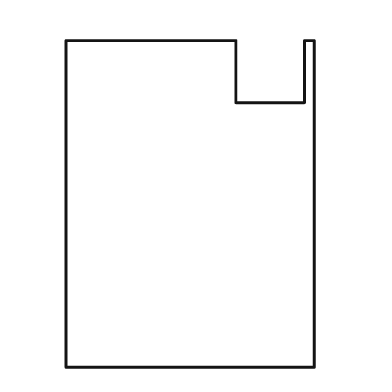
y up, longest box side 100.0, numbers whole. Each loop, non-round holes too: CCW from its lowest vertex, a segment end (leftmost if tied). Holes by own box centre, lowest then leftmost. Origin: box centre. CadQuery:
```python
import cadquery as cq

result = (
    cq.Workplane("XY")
    .moveTo(-38.0, -50.0)
    .lineTo(38.0, -50.0)
    .lineTo(38.0, 50.0)
    .lineTo(35.0, 50.0)
    .lineTo(35.0, 31.0)
    .lineTo(14.0, 31.0)
    .lineTo(14.0, 50.0)
    .lineTo(-38.0, 50.0)
    .close()
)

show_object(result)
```